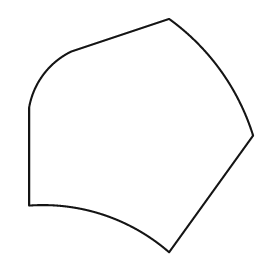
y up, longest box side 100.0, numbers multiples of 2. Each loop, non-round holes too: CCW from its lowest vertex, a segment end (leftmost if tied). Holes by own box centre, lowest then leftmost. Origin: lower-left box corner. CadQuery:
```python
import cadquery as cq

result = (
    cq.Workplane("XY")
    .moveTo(60.0, 0.0)
    .lineTo(96.0, 50.0)
    .threePointArc((82.0, 78.0), (60.0, 100.0))
    .lineTo(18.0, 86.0)
    .threePointArc((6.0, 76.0), (0.0, 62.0))
    .lineTo(0.0, 20.0)
    .threePointArc((32.0, 16.0), (60.0, 0.0))
    .close()
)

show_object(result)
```